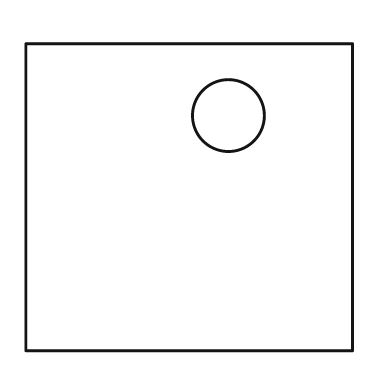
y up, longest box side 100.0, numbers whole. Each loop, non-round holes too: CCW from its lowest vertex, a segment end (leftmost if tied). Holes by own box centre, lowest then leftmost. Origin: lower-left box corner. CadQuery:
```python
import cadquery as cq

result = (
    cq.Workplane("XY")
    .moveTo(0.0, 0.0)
    .lineTo(100.0, 0.0)
    .lineTo(100.0, 94.0)
    .lineTo(0.0, 94.0)
    .close()
    .moveTo(62.0, 72.0)
    .circle(11.0)
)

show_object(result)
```